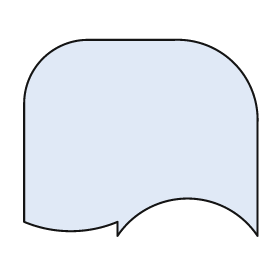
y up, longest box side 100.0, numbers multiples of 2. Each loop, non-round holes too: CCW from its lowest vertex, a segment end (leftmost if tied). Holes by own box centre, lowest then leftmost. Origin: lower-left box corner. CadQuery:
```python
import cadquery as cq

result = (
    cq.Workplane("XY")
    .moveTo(40.0, 0.0)
    .threePointArc((70.0, 16.0), (100.0, 0.0))
    .lineTo(100.0, 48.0)
    .threePointArc((90.0, 74.0), (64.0, 84.0))
    .lineTo(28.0, 84.0)
    .threePointArc((8.0, 76.0), (0.0, 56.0))
    .lineTo(0.0, 6.0)
    .threePointArc((20.0, 2.0), (40.0, 6.0))
    .close()
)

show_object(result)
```